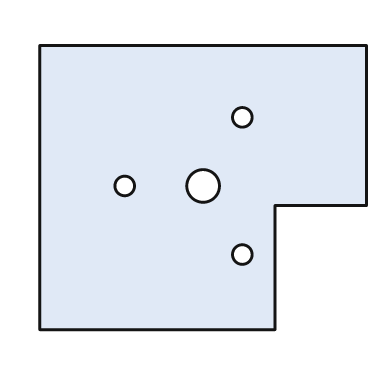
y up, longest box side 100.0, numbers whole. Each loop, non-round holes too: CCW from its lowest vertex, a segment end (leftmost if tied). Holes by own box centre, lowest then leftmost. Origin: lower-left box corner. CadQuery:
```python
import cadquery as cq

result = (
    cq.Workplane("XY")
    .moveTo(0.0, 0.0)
    .lineTo(72.0, 0.0)
    .lineTo(72.0, 38.0)
    .lineTo(100.0, 38.0)
    .lineTo(100.0, 87.0)
    .lineTo(0.0, 87.0)
    .close()
    .moveTo(62.0, 23.0)
    .circle(3.0)
    .moveTo(26.0, 44.0)
    .circle(3.0)
    .moveTo(50.0, 44.0)
    .circle(5.0)
    .moveTo(62.0, 65.0)
    .circle(3.0)
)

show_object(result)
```